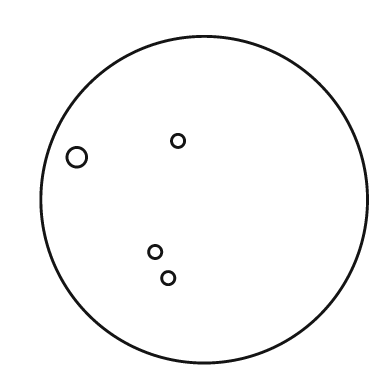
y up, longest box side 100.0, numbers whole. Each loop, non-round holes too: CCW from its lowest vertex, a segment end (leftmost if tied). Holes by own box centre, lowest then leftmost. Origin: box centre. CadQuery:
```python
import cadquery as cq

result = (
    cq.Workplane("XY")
    .moveTo(0.0, 0.0)
    .circle(50.0)
    .moveTo(-11.0, -24.0)
    .circle(2.0)
    .moveTo(-15.0, -16.0)
    .circle(2.0)
    .moveTo(-39.0, 13.0)
    .circle(3.0)
    .moveTo(-8.0, 18.0)
    .circle(2.0)
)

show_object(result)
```